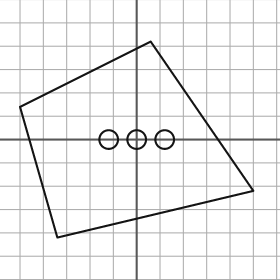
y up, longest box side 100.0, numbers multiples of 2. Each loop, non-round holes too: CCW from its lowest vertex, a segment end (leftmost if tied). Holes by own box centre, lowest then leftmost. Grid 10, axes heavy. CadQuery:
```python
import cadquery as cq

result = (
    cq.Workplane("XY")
    .moveTo(-34.0, -42.0)
    .lineTo(50.0, -22.0)
    .lineTo(6.0, 42.0)
    .lineTo(-50.0, 14.0)
    .close()
    .moveTo(-12.0, 0.0)
    .circle(4.0)
    .moveTo(0.0, 0.0)
    .circle(4.0)
    .moveTo(12.0, 0.0)
    .circle(4.0)
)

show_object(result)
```